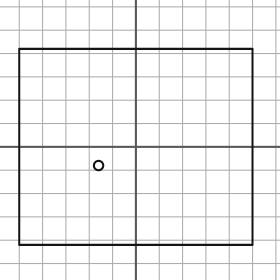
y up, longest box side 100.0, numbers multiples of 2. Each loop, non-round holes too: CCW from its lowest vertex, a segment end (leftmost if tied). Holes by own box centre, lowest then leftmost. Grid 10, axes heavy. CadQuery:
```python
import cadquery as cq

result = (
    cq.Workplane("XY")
    .moveTo(-50.0, -42.0)
    .lineTo(50.0, -42.0)
    .lineTo(50.0, 42.0)
    .lineTo(-50.0, 42.0)
    .close()
    .moveTo(-16.0, -8.0)
    .circle(2.0)
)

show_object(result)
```